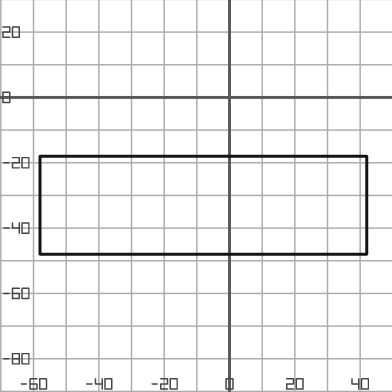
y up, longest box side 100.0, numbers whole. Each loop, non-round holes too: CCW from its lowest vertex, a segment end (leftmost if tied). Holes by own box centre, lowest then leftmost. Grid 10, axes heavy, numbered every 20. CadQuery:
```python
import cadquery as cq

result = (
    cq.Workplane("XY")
    .moveTo(-58.0, -48.0)
    .lineTo(42.0, -48.0)
    .lineTo(42.0, -18.0)
    .lineTo(-58.0, -18.0)
    .close()
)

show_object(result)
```